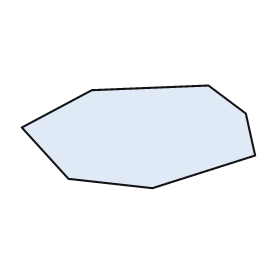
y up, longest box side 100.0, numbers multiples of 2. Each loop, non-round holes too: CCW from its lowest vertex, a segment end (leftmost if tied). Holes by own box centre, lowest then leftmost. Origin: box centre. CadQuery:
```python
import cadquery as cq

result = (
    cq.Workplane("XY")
    .moveTo(6.0, -22.0)
    .lineTo(50.0, -8.0)
    .lineTo(46.0, 10.0)
    .lineTo(30.0, 22.0)
    .lineTo(-20.0, 20.0)
    .lineTo(-50.0, 4.0)
    .lineTo(-30.0, -18.0)
    .close()
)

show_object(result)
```